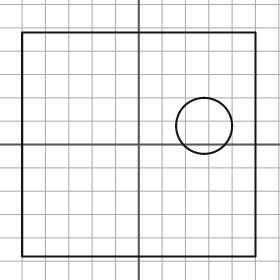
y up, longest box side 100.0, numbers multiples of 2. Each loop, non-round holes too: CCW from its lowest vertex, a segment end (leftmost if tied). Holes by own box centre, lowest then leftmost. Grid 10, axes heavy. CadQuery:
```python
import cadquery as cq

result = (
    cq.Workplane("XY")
    .moveTo(-50.0, -48.0)
    .lineTo(50.0, -48.0)
    .lineTo(50.0, 48.0)
    .lineTo(-50.0, 48.0)
    .close()
    .moveTo(28.0, 8.0)
    .circle(12.0)
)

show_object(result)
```